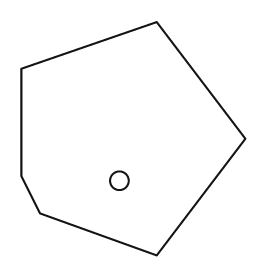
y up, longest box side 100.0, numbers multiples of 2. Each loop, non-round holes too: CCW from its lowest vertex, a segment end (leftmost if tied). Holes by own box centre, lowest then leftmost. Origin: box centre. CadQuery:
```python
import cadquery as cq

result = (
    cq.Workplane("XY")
    .moveTo(10.0, -50.0)
    .lineTo(48.0, 0.0)
    .lineTo(10.0, 50.0)
    .lineTo(-48.0, 30.0)
    .lineTo(-48.0, -16.0)
    .lineTo(-40.0, -32.0)
    .close()
    .moveTo(-6.0, -18.0)
    .circle(4.0)
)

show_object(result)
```